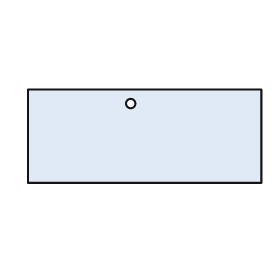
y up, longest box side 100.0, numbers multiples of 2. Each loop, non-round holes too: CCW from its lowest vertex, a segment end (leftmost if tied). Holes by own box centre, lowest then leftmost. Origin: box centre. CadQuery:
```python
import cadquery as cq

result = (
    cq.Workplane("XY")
    .moveTo(-50.0, -20.0)
    .lineTo(50.0, -20.0)
    .lineTo(50.0, 20.0)
    .lineTo(-50.0, 20.0)
    .close()
    .moveTo(-6.0, 14.0)
    .circle(2.0)
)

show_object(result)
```